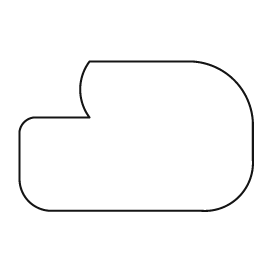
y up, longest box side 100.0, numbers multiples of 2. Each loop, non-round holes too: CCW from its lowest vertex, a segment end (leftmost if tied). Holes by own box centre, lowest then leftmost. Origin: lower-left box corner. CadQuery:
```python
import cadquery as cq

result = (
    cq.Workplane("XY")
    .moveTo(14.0, 0.0)
    .lineTo(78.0, 0.0)
    .threePointArc((94.0, 6.0), (100.0, 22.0))
    .lineTo(100.0, 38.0)
    .threePointArc((92.0, 56.0), (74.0, 64.0))
    .lineTo(30.0, 64.0)
    .threePointArc((26.0, 52.0), (30.0, 40.0))
    .lineTo(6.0, 40.0)
    .threePointArc((2.0, 38.0), (0.0, 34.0))
    .lineTo(0.0, 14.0)
    .threePointArc((4.0, 4.0), (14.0, 0.0))
    .close()
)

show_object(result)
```